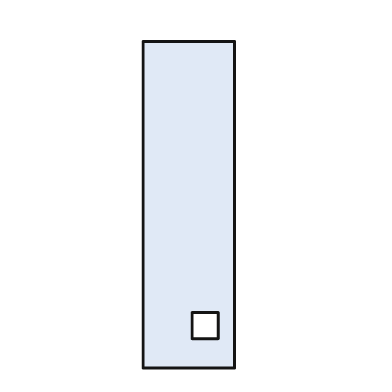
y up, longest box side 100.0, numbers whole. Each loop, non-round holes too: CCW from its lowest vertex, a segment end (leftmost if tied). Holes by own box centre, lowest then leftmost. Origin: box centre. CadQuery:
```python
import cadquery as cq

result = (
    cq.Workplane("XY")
    .moveTo(-14.0, -50.0)
    .lineTo(14.0, -50.0)
    .lineTo(14.0, 50.0)
    .lineTo(-14.0, 50.0)
    .close()
    .moveTo(1.0, -41.0)
    .lineTo(9.0, -41.0)
    .lineTo(9.0, -33.0)
    .lineTo(1.0, -33.0)
    .close()
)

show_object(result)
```